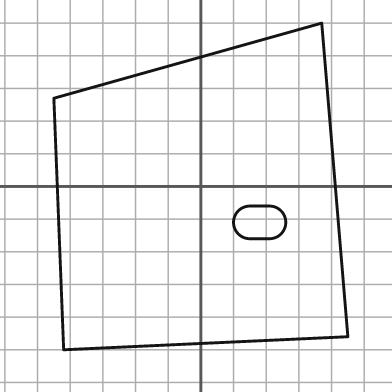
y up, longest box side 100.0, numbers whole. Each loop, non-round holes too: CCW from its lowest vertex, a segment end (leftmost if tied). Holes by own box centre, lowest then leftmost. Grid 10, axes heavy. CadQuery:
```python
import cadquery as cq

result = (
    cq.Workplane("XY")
    .moveTo(-42.0, -50.0)
    .lineTo(45.0, -46.0)
    .lineTo(37.0, 50.0)
    .lineTo(-45.0, 27.0)
    .close()
    .moveTo(15.0, -16.0)
    .lineTo(21.0, -16.0)
    .threePointArc((26.0, -11.0), (21.0, -6.0))
    .lineTo(15.0, -6.0)
    .threePointArc((10.0, -11.0), (15.0, -16.0))
    .close()
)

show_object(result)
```